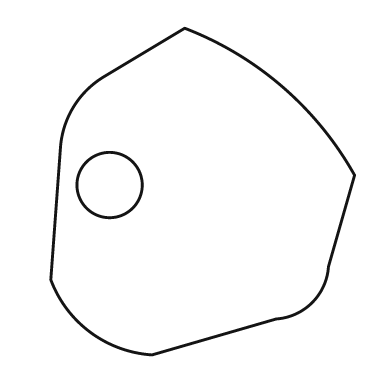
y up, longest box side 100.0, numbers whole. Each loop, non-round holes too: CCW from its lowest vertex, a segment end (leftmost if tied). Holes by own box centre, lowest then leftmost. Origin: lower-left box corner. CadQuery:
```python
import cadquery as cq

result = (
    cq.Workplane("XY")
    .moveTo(31.0, 0.0)
    .lineTo(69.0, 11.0)
    .threePointArc((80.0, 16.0), (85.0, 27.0))
    .lineTo(93.0, 55.0)
    .threePointArc((71.0, 82.0), (41.0, 100.0))
    .lineTo(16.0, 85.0)
    .threePointArc((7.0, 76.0), (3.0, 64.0))
    .lineTo(0.0, 23.0)
    .threePointArc((12.0, 7.0), (31.0, 0.0))
    .close()
    .moveTo(18.0, 52.0)
    .circle(10.0)
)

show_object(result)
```